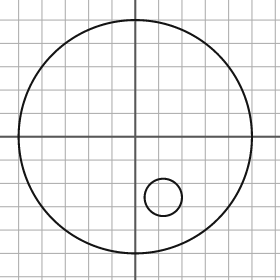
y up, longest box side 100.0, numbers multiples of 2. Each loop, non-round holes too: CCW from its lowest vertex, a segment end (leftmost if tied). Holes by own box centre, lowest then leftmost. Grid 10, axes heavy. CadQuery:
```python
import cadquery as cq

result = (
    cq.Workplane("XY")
    .moveTo(0.0, 0.0)
    .circle(50.0)
    .moveTo(12.0, -26.0)
    .circle(8.0)
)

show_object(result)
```